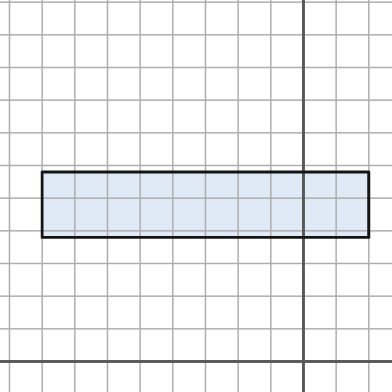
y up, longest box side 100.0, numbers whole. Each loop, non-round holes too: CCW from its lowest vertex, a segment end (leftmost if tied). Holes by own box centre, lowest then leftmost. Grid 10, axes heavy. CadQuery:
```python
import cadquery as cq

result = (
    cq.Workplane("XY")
    .moveTo(-80.0, 38.0)
    .lineTo(20.0, 38.0)
    .lineTo(20.0, 58.0)
    .lineTo(-80.0, 58.0)
    .close()
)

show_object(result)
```